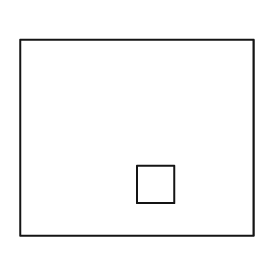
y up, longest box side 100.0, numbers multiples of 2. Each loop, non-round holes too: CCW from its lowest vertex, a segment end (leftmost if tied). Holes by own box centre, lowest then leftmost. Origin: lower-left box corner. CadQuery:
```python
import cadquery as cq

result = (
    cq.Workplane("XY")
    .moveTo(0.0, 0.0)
    .lineTo(100.0, 0.0)
    .lineTo(100.0, 84.0)
    .lineTo(0.0, 84.0)
    .close()
    .moveTo(50.0, 14.0)
    .lineTo(66.0, 14.0)
    .lineTo(66.0, 30.0)
    .lineTo(50.0, 30.0)
    .close()
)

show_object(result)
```